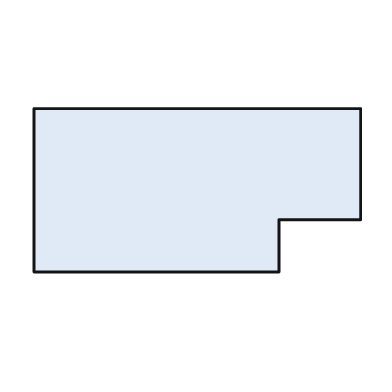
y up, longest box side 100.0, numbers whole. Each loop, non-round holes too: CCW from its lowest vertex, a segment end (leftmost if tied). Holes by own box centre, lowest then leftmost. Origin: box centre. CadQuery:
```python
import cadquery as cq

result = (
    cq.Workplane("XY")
    .moveTo(-50.0, -25.0)
    .lineTo(25.0, -25.0)
    .lineTo(25.0, -9.0)
    .lineTo(50.0, -9.0)
    .lineTo(50.0, 25.0)
    .lineTo(-50.0, 25.0)
    .close()
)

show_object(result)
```